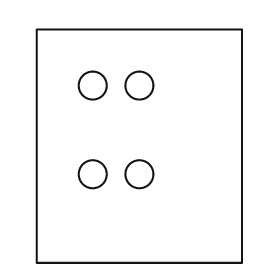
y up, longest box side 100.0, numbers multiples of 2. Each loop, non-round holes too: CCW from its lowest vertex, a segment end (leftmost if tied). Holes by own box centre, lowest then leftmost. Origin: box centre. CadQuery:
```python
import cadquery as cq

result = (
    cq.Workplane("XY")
    .moveTo(-44.0, -50.0)
    .lineTo(44.0, -50.0)
    .lineTo(44.0, 50.0)
    .lineTo(-44.0, 50.0)
    .close()
    .moveTo(-20.0, -12.0)
    .circle(6.0)
    .moveTo(0.0, -12.0)
    .circle(6.0)
    .moveTo(-20.0, 26.0)
    .circle(6.0)
    .moveTo(0.0, 26.0)
    .circle(6.0)
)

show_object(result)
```